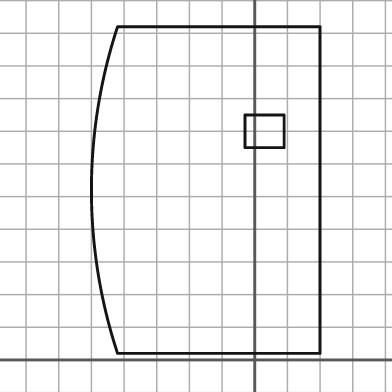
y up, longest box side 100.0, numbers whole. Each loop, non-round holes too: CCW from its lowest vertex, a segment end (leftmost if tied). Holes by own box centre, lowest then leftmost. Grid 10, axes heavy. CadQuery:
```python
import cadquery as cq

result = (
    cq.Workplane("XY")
    .moveTo(-42.0, 2.0)
    .lineTo(20.0, 2.0)
    .lineTo(20.0, 102.0)
    .lineTo(-42.0, 102.0)
    .threePointArc((-50.0, 52.0), (-42.0, 2.0))
    .close()
    .moveTo(-3.0, 65.0)
    .lineTo(9.0, 65.0)
    .lineTo(9.0, 75.0)
    .lineTo(-3.0, 75.0)
    .close()
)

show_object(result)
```